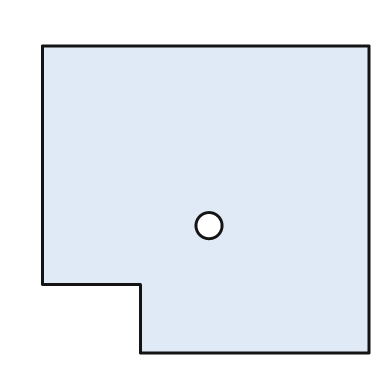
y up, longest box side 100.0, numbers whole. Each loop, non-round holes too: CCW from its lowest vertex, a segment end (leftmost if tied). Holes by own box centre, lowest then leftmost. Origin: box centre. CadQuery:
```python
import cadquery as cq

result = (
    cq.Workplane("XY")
    .moveTo(-20.0, -47.0)
    .lineTo(50.0, -47.0)
    .lineTo(50.0, 47.0)
    .lineTo(-50.0, 47.0)
    .lineTo(-50.0, -26.0)
    .lineTo(-20.0, -26.0)
    .close()
    .moveTo(1.0, -8.0)
    .circle(4.0)
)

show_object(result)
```